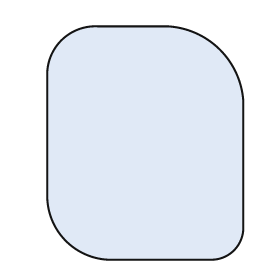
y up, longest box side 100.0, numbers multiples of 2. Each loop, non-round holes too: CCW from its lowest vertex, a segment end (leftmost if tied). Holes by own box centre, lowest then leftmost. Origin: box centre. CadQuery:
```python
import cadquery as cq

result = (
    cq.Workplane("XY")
    .moveTo(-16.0, -50.0)
    .lineTo(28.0, -50.0)
    .threePointArc((38.0, -46.0), (42.0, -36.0))
    .lineTo(42.0, 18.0)
    .threePointArc((32.0, 40.0), (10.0, 50.0))
    .lineTo(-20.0, 50.0)
    .threePointArc((-36.0, 44.0), (-42.0, 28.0))
    .lineTo(-42.0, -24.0)
    .threePointArc((-34.0, -42.0), (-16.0, -50.0))
    .close()
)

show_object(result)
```